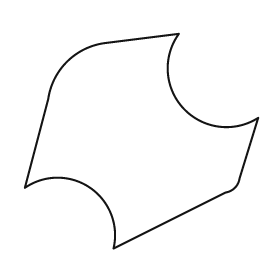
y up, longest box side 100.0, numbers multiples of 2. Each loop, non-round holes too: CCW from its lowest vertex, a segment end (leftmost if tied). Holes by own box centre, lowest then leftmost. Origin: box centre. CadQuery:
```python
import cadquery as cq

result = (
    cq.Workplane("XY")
    .moveTo(-12.0, -46.0)
    .lineTo(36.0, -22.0)
    .threePointArc((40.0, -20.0), (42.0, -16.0))
    .lineTo(50.0, 10.0)
    .threePointArc((18.0, 14.0), (16.0, 46.0))
    .lineTo(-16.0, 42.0)
    .threePointArc((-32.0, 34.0), (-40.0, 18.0))
    .lineTo(-50.0, -20.0)
    .threePointArc((-22.0, -20.0), (-12.0, -46.0))
    .close()
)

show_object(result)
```